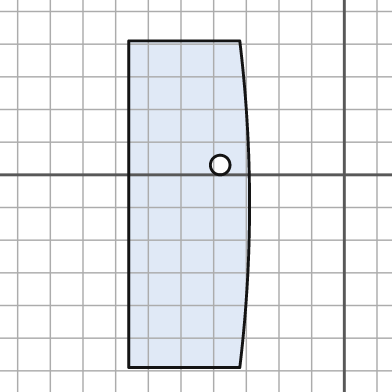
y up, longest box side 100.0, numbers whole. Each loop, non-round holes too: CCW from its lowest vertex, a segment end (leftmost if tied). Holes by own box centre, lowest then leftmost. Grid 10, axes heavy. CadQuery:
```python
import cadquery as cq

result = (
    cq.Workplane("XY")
    .moveTo(-66.0, -59.0)
    .lineTo(-32.0, -59.0)
    .threePointArc((-29.0, -9.0), (-32.0, 41.0))
    .lineTo(-66.0, 41.0)
    .close()
    .moveTo(-38.0, 3.0)
    .circle(3.0)
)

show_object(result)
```